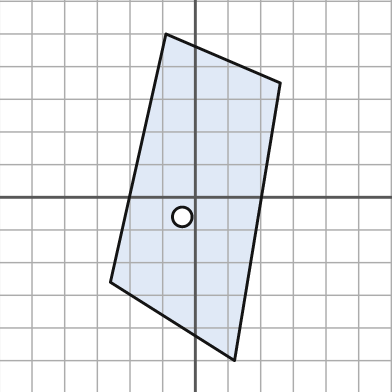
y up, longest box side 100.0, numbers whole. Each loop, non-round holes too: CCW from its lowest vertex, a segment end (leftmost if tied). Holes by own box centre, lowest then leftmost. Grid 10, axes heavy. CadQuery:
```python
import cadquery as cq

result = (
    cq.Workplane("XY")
    .moveTo(12.0, -50.0)
    .lineTo(26.0, 35.0)
    .lineTo(-9.0, 50.0)
    .lineTo(-26.0, -26.0)
    .close()
    .moveTo(-4.0, -6.0)
    .circle(3.0)
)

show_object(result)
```